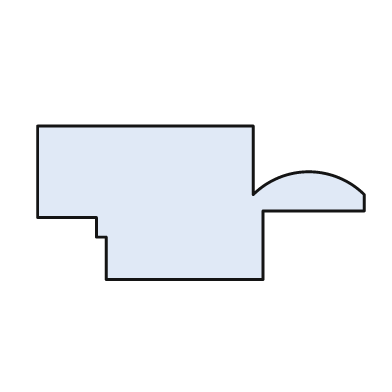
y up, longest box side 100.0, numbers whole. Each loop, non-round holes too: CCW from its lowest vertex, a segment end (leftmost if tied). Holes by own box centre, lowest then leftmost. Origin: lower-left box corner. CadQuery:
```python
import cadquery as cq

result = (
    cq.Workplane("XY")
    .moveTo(21.0, 0.0)
    .lineTo(69.0, 0.0)
    .lineTo(69.0, 21.0)
    .lineTo(100.0, 21.0)
    .lineTo(100.0, 26.0)
    .threePointArc((83.0, 33.0), (66.0, 26.0))
    .lineTo(66.0, 47.0)
    .lineTo(0.0, 47.0)
    .lineTo(0.0, 19.0)
    .lineTo(18.0, 19.0)
    .lineTo(18.0, 13.0)
    .lineTo(21.0, 13.0)
    .close()
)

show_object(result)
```